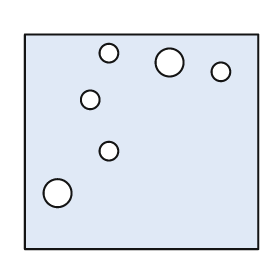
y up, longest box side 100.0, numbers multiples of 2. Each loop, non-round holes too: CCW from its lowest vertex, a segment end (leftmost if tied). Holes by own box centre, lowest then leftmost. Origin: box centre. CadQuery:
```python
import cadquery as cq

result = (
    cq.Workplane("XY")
    .moveTo(-50.0, -46.0)
    .lineTo(50.0, -46.0)
    .lineTo(50.0, 46.0)
    .lineTo(-50.0, 46.0)
    .close()
    .moveTo(-36.0, -22.0)
    .circle(6.0)
    .moveTo(-14.0, -4.0)
    .circle(4.0)
    .moveTo(-22.0, 18.0)
    .circle(4.0)
    .moveTo(34.0, 30.0)
    .circle(4.0)
    .moveTo(12.0, 34.0)
    .circle(6.0)
    .moveTo(-14.0, 38.0)
    .circle(4.0)
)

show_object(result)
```